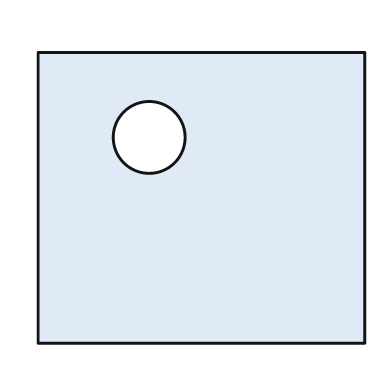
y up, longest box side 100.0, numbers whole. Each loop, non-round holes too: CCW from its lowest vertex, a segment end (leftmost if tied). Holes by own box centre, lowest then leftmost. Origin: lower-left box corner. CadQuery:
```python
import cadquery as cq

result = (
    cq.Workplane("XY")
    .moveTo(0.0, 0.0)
    .lineTo(100.0, 0.0)
    .lineTo(100.0, 89.0)
    .lineTo(0.0, 89.0)
    .close()
    .moveTo(34.0, 63.0)
    .circle(11.0)
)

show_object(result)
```